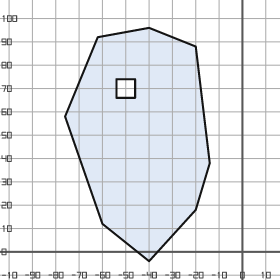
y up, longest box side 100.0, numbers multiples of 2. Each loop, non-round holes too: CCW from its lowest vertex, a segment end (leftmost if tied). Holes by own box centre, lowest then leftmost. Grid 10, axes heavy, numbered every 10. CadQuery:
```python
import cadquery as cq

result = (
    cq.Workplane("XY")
    .moveTo(-40.0, -4.0)
    .lineTo(-20.0, 18.0)
    .lineTo(-14.0, 38.0)
    .lineTo(-20.0, 88.0)
    .lineTo(-40.0, 96.0)
    .lineTo(-62.0, 92.0)
    .lineTo(-76.0, 58.0)
    .lineTo(-60.0, 12.0)
    .close()
    .moveTo(-54.0, 66.0)
    .lineTo(-46.0, 66.0)
    .lineTo(-46.0, 74.0)
    .lineTo(-54.0, 74.0)
    .close()
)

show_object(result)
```